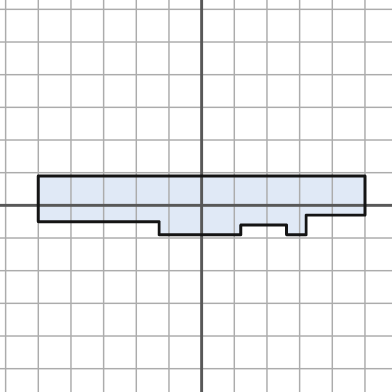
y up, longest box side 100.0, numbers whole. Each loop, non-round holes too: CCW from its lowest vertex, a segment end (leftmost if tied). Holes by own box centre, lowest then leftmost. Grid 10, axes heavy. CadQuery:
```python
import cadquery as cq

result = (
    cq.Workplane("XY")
    .moveTo(-13.0, -9.0)
    .lineTo(12.0, -9.0)
    .lineTo(12.0, -6.0)
    .lineTo(26.0, -6.0)
    .lineTo(26.0, -9.0)
    .lineTo(32.0, -9.0)
    .lineTo(32.0, -3.0)
    .lineTo(50.0, -3.0)
    .lineTo(50.0, 9.0)
    .lineTo(-50.0, 9.0)
    .lineTo(-50.0, -5.0)
    .lineTo(-13.0, -5.0)
    .close()
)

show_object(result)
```